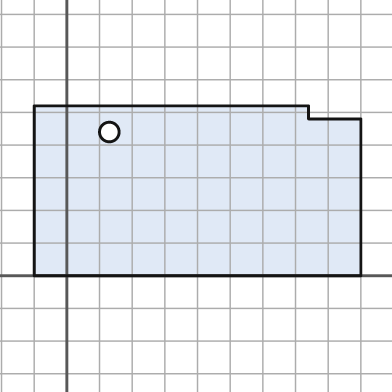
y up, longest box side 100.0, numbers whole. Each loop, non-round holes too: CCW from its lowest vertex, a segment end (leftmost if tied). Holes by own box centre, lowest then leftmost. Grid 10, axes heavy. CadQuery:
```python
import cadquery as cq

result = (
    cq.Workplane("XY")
    .moveTo(-10.0, 0.0)
    .lineTo(90.0, 0.0)
    .lineTo(90.0, 48.0)
    .lineTo(74.0, 48.0)
    .lineTo(74.0, 52.0)
    .lineTo(-10.0, 52.0)
    .close()
    .moveTo(13.0, 44.0)
    .circle(3.0)
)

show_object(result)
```